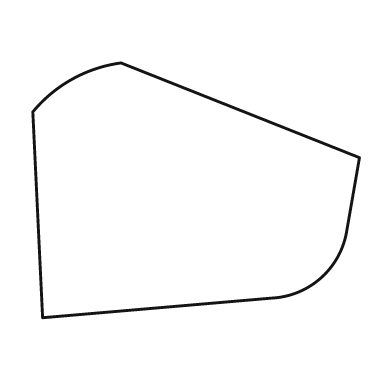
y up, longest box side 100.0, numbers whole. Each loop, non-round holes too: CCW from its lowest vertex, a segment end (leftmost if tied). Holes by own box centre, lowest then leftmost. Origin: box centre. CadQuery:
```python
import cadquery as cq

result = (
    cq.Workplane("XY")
    .moveTo(-47.0, -39.0)
    .lineTo(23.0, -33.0)
    .threePointArc((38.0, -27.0), (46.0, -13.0))
    .lineTo(50.0, 10.0)
    .lineTo(-23.0, 39.0)
    .threePointArc((-38.0, 34.0), (-50.0, 24.0))
    .close()
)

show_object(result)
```